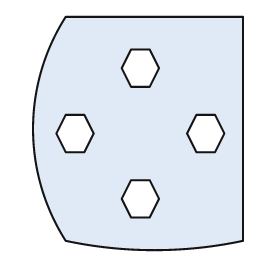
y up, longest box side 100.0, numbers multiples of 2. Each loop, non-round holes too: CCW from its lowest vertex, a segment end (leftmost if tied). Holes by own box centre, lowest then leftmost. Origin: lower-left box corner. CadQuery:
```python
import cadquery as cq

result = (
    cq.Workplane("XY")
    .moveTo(14.0, 4.0)
    .threePointArc((52.0, 0.0), (90.0, 4.0))
    .lineTo(90.0, 100.0)
    .lineTo(14.0, 100.0)
    .threePointArc((0.0, 52.0), (14.0, 4.0))
    .close()
    .moveTo(42.0, 14.0)
    .lineTo(50.0, 14.0)
    .lineTo(54.0, 22.0)
    .lineTo(50.0, 30.0)
    .lineTo(42.0, 30.0)
    .lineTo(38.0, 22.0)
    .close()
    .moveTo(14.0, 42.0)
    .lineTo(22.0, 42.0)
    .lineTo(26.0, 50.0)
    .lineTo(22.0, 58.0)
    .lineTo(14.0, 58.0)
    .lineTo(10.0, 50.0)
    .close()
    .moveTo(70.0, 42.0)
    .lineTo(78.0, 42.0)
    .lineTo(82.0, 50.0)
    .lineTo(78.0, 58.0)
    .lineTo(70.0, 58.0)
    .lineTo(66.0, 50.0)
    .close()
    .moveTo(42.0, 70.0)
    .lineTo(50.0, 70.0)
    .lineTo(54.0, 78.0)
    .lineTo(50.0, 86.0)
    .lineTo(42.0, 86.0)
    .lineTo(38.0, 78.0)
    .close()
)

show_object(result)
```